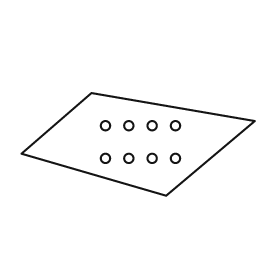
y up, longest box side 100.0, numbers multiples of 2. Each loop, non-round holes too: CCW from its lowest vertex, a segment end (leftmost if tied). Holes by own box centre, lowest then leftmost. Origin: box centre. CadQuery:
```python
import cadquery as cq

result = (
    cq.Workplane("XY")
    .moveTo(12.0, -22.0)
    .lineTo(50.0, 10.0)
    .lineTo(-20.0, 22.0)
    .lineTo(-50.0, -4.0)
    .close()
    .moveTo(-14.0, -6.0)
    .circle(2.0)
    .moveTo(-4.0, -6.0)
    .circle(2.0)
    .moveTo(6.0, -6.0)
    .circle(2.0)
    .moveTo(16.0, -6.0)
    .circle(2.0)
    .moveTo(-14.0, 8.0)
    .circle(2.0)
    .moveTo(-4.0, 8.0)
    .circle(2.0)
    .moveTo(6.0, 8.0)
    .circle(2.0)
    .moveTo(16.0, 8.0)
    .circle(2.0)
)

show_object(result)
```